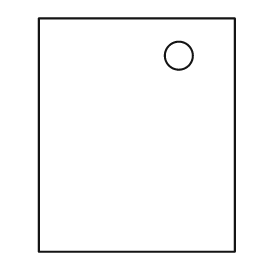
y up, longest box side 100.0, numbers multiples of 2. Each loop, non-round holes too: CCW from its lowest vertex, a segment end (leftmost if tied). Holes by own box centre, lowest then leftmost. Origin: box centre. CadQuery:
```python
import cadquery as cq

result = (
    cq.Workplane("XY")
    .moveTo(-42.0, -50.0)
    .lineTo(42.0, -50.0)
    .lineTo(42.0, 50.0)
    .lineTo(-42.0, 50.0)
    .close()
    .moveTo(18.0, 34.0)
    .circle(6.0)
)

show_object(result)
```